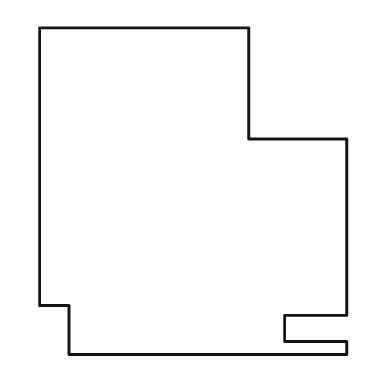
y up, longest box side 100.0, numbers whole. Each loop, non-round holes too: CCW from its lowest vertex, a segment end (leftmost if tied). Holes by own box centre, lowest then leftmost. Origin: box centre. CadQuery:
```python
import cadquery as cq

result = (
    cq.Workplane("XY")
    .moveTo(-38.0, -50.0)
    .lineTo(47.0, -50.0)
    .lineTo(47.0, -46.0)
    .lineTo(28.0, -46.0)
    .lineTo(28.0, -38.0)
    .lineTo(47.0, -38.0)
    .lineTo(47.0, 16.0)
    .lineTo(17.0, 16.0)
    .lineTo(17.0, 50.0)
    .lineTo(-47.0, 50.0)
    .lineTo(-47.0, -35.0)
    .lineTo(-38.0, -35.0)
    .close()
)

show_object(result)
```